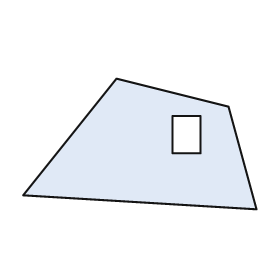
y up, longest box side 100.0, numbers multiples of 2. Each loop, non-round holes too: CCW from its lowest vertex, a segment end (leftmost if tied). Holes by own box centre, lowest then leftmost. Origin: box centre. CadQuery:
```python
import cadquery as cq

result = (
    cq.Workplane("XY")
    .moveTo(50.0, -28.0)
    .lineTo(38.0, 16.0)
    .lineTo(-10.0, 28.0)
    .lineTo(-50.0, -22.0)
    .close()
    .moveTo(14.0, -4.0)
    .lineTo(26.0, -4.0)
    .lineTo(26.0, 12.0)
    .lineTo(14.0, 12.0)
    .close()
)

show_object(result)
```